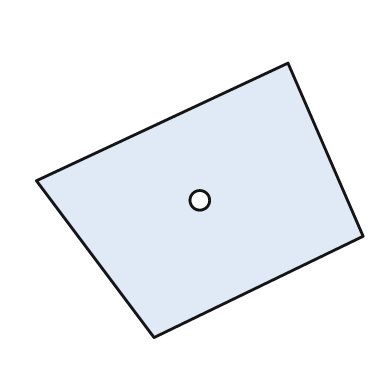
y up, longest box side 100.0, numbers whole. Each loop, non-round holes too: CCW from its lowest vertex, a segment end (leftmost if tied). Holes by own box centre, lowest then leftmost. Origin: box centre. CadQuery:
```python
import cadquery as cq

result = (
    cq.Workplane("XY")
    .moveTo(-14.0, -42.0)
    .lineTo(50.0, -11.0)
    .lineTo(27.0, 42.0)
    .lineTo(-50.0, 6.0)
    .close()
    .moveTo(0.0, 0.0)
    .circle(3.0)
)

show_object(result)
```